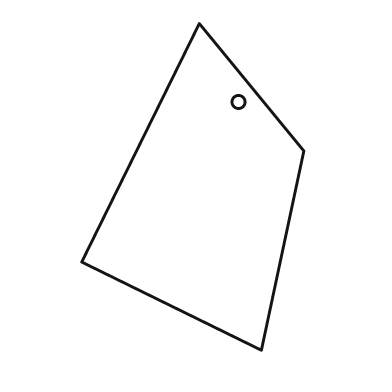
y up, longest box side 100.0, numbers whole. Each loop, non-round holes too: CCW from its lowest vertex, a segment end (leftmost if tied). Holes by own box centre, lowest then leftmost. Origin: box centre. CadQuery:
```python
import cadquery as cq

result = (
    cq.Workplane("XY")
    .moveTo(21.0, -50.0)
    .lineTo(34.0, 11.0)
    .lineTo(2.0, 50.0)
    .lineTo(-34.0, -23.0)
    .close()
    .moveTo(14.0, 26.0)
    .circle(2.0)
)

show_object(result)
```